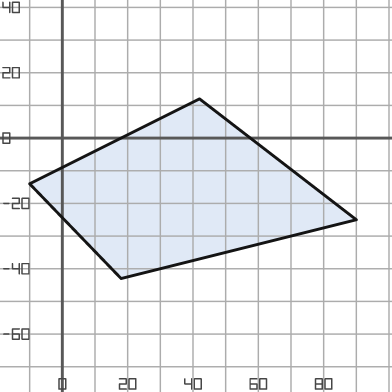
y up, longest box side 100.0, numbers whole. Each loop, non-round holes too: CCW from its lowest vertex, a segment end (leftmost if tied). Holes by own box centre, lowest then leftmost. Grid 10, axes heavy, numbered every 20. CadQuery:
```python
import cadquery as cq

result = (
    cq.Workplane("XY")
    .moveTo(18.0, -43.0)
    .lineTo(90.0, -25.0)
    .lineTo(42.0, 12.0)
    .lineTo(-10.0, -14.0)
    .close()
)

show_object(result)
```